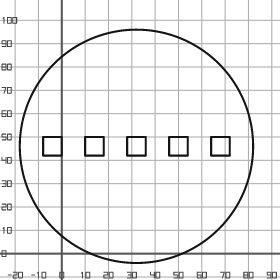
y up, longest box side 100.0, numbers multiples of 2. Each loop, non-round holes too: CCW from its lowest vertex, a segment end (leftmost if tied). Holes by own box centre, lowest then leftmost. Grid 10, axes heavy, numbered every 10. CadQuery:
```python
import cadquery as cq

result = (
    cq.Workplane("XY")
    .moveTo(32.0, 46.0)
    .circle(50.0)
    .moveTo(-8.0, 42.0)
    .lineTo(0.0, 42.0)
    .lineTo(0.0, 50.0)
    .lineTo(-8.0, 50.0)
    .close()
    .moveTo(10.0, 42.0)
    .lineTo(18.0, 42.0)
    .lineTo(18.0, 50.0)
    .lineTo(10.0, 50.0)
    .close()
    .moveTo(28.0, 42.0)
    .lineTo(36.0, 42.0)
    .lineTo(36.0, 50.0)
    .lineTo(28.0, 50.0)
    .close()
    .moveTo(46.0, 42.0)
    .lineTo(54.0, 42.0)
    .lineTo(54.0, 50.0)
    .lineTo(46.0, 50.0)
    .close()
    .moveTo(64.0, 42.0)
    .lineTo(72.0, 42.0)
    .lineTo(72.0, 50.0)
    .lineTo(64.0, 50.0)
    .close()
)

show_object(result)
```